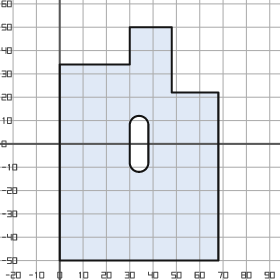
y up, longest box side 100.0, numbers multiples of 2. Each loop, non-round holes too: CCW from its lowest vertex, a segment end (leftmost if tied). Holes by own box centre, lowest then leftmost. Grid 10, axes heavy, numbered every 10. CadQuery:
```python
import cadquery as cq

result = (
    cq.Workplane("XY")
    .moveTo(0.0, -50.0)
    .lineTo(68.0, -50.0)
    .lineTo(68.0, 22.0)
    .lineTo(48.0, 22.0)
    .lineTo(48.0, 50.0)
    .lineTo(30.0, 50.0)
    .lineTo(30.0, 34.0)
    .lineTo(0.0, 34.0)
    .close()
    .moveTo(30.0, -8.0)
    .threePointArc((34.0, -12.0), (38.0, -8.0))
    .lineTo(38.0, 8.0)
    .threePointArc((34.0, 12.0), (30.0, 8.0))
    .close()
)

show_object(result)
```